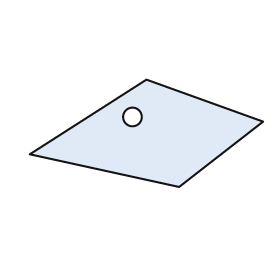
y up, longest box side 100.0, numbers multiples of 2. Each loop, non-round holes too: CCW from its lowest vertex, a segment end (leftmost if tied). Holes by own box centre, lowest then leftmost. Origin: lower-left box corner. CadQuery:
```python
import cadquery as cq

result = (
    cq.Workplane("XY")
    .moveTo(64.0, 0.0)
    .lineTo(100.0, 28.0)
    .lineTo(50.0, 46.0)
    .lineTo(0.0, 14.0)
    .close()
    .moveTo(44.0, 30.0)
    .circle(4.0)
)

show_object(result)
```